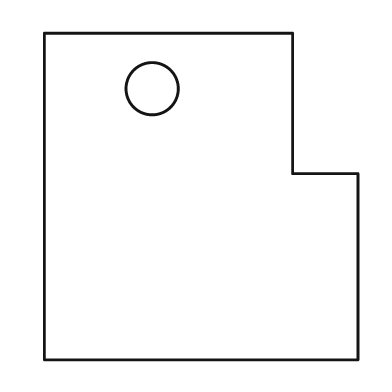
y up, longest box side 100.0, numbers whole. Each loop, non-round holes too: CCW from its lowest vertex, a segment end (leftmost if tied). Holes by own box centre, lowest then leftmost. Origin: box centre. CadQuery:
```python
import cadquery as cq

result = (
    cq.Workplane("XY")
    .moveTo(-48.0, -50.0)
    .lineTo(48.0, -50.0)
    .lineTo(48.0, 7.0)
    .lineTo(28.0, 7.0)
    .lineTo(28.0, 50.0)
    .lineTo(-48.0, 50.0)
    .close()
    .moveTo(-15.0, 33.0)
    .circle(8.0)
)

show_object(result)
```